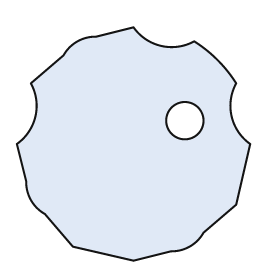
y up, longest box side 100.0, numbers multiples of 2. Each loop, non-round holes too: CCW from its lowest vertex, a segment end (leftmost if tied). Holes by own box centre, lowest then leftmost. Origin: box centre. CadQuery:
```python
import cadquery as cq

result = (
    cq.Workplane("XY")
    .moveTo(0.0, -50.0)
    .lineTo(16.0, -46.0)
    .threePointArc((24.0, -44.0), (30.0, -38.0))
    .lineTo(44.0, -26.0)
    .lineTo(50.0, 0.0)
    .threePointArc((42.0, 12.0), (44.0, 26.0))
    .threePointArc((36.0, 36.0), (26.0, 44.0))
    .threePointArc((12.0, 42.0), (0.0, 50.0))
    .lineTo(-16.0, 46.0)
    .threePointArc((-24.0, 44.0), (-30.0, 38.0))
    .lineTo(-44.0, 26.0)
    .threePointArc((-42.0, 12.0), (-50.0, 0.0))
    .lineTo(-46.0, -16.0)
    .threePointArc((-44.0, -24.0), (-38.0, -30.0))
    .lineTo(-26.0, -44.0)
    .close()
    .moveTo(22.0, 10.0)
    .circle(8.0)
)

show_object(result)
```